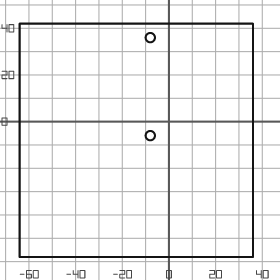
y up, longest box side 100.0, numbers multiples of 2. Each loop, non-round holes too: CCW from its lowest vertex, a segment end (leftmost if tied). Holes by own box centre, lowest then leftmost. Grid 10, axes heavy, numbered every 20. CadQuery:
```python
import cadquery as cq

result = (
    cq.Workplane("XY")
    .moveTo(-64.0, -58.0)
    .lineTo(36.0, -58.0)
    .lineTo(36.0, 42.0)
    .lineTo(-64.0, 42.0)
    .close()
    .moveTo(-8.0, -6.0)
    .circle(2.0)
    .moveTo(-8.0, 36.0)
    .circle(2.0)
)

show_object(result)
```